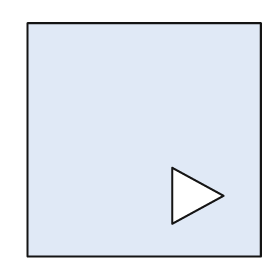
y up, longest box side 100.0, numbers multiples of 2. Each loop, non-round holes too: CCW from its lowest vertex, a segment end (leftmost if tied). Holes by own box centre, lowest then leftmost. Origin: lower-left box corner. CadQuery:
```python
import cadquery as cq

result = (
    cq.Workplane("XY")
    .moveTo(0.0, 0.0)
    .lineTo(100.0, 0.0)
    .lineTo(100.0, 100.0)
    .lineTo(0.0, 100.0)
    .close()
    .moveTo(62.0, 14.0)
    .lineTo(84.0, 26.0)
    .lineTo(62.0, 38.0)
    .close()
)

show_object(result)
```